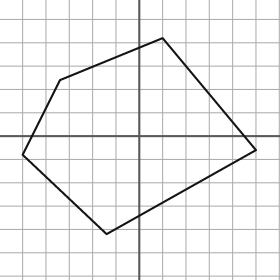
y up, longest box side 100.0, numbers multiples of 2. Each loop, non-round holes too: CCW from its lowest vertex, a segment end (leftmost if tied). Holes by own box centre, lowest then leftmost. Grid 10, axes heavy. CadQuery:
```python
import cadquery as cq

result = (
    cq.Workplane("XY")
    .moveTo(-14.0, -42.0)
    .lineTo(50.0, -6.0)
    .lineTo(10.0, 42.0)
    .lineTo(-34.0, 24.0)
    .lineTo(-50.0, -8.0)
    .close()
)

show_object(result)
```